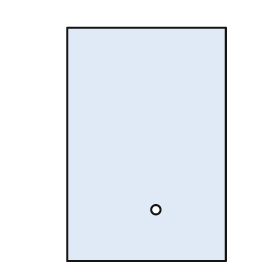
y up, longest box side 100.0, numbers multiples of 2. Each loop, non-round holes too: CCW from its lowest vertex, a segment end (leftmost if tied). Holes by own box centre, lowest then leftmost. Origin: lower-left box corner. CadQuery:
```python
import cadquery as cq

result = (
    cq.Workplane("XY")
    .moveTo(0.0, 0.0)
    .lineTo(68.0, 0.0)
    .lineTo(68.0, 100.0)
    .lineTo(0.0, 100.0)
    .close()
    .moveTo(38.0, 22.0)
    .circle(2.0)
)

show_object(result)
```